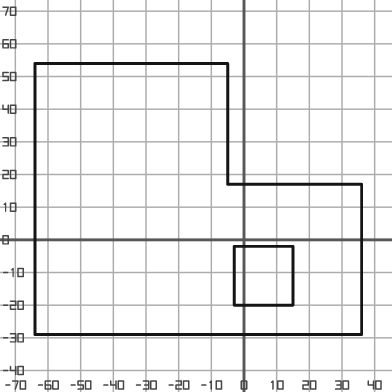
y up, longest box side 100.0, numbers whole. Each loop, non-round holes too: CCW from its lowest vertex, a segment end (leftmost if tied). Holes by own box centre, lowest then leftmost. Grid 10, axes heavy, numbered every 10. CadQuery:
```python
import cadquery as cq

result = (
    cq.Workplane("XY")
    .moveTo(-64.0, -29.0)
    .lineTo(36.0, -29.0)
    .lineTo(36.0, 17.0)
    .lineTo(-5.0, 17.0)
    .lineTo(-5.0, 54.0)
    .lineTo(-64.0, 54.0)
    .close()
    .moveTo(-3.0, -20.0)
    .lineTo(15.0, -20.0)
    .lineTo(15.0, -2.0)
    .lineTo(-3.0, -2.0)
    .close()
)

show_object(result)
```